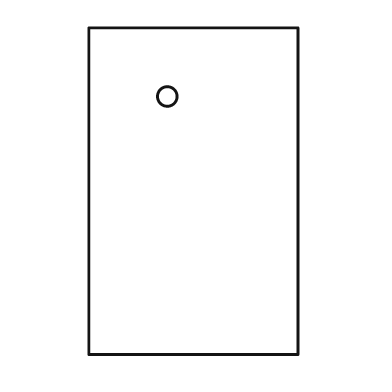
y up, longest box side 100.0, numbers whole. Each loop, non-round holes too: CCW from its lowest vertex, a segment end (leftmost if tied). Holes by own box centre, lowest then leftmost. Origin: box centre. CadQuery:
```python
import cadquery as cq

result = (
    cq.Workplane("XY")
    .moveTo(-32.0, -50.0)
    .lineTo(32.0, -50.0)
    .lineTo(32.0, 50.0)
    .lineTo(-32.0, 50.0)
    .close()
    .moveTo(-8.0, 29.0)
    .circle(3.0)
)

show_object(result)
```